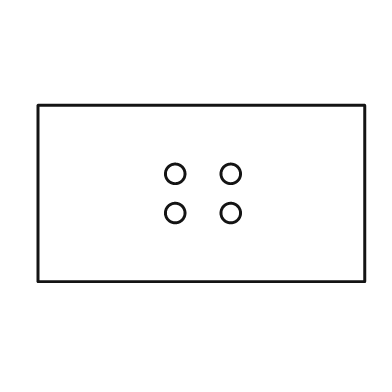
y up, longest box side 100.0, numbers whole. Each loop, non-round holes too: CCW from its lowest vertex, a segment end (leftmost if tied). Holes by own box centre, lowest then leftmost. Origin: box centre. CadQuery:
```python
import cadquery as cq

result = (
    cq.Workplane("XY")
    .moveTo(-50.0, -27.0)
    .lineTo(50.0, -27.0)
    .lineTo(50.0, 27.0)
    .lineTo(-50.0, 27.0)
    .close()
    .moveTo(-8.0, -6.0)
    .circle(3.0)
    .moveTo(9.0, -6.0)
    .circle(3.0)
    .moveTo(-8.0, 6.0)
    .circle(3.0)
    .moveTo(9.0, 6.0)
    .circle(3.0)
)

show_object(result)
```